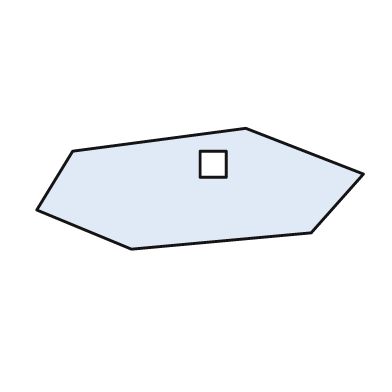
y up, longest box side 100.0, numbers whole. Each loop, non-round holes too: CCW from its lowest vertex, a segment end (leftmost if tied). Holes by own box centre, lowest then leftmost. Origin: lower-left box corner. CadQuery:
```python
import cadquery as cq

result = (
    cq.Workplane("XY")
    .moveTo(29.0, 0.0)
    .lineTo(84.0, 5.0)
    .lineTo(100.0, 23.0)
    .lineTo(64.0, 37.0)
    .lineTo(11.0, 30.0)
    .lineTo(0.0, 12.0)
    .close()
    .moveTo(50.0, 22.0)
    .lineTo(58.0, 22.0)
    .lineTo(58.0, 30.0)
    .lineTo(50.0, 30.0)
    .close()
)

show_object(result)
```